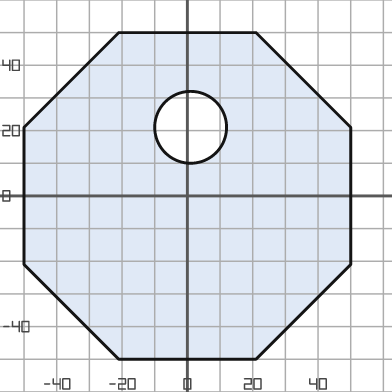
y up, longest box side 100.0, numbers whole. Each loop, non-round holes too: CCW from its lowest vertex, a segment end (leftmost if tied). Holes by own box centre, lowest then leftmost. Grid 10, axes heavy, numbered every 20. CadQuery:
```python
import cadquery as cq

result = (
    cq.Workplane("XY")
    .moveTo(-21.0, -50.0)
    .lineTo(21.0, -50.0)
    .lineTo(50.0, -21.0)
    .lineTo(50.0, 21.0)
    .lineTo(21.0, 50.0)
    .lineTo(-21.0, 50.0)
    .lineTo(-50.0, 21.0)
    .lineTo(-50.0, -21.0)
    .close()
    .moveTo(1.0, 21.0)
    .circle(11.0)
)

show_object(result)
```